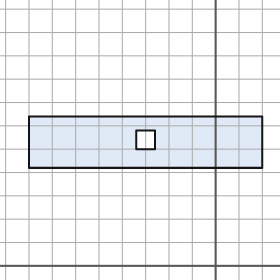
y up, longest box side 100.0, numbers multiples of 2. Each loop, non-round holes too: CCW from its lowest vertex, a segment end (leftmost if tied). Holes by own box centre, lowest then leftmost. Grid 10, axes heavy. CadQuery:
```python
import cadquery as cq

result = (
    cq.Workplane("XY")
    .moveTo(-80.0, 42.0)
    .lineTo(20.0, 42.0)
    .lineTo(20.0, 64.0)
    .lineTo(-80.0, 64.0)
    .close()
    .moveTo(-34.0, 50.0)
    .lineTo(-26.0, 50.0)
    .lineTo(-26.0, 58.0)
    .lineTo(-34.0, 58.0)
    .close()
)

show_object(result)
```